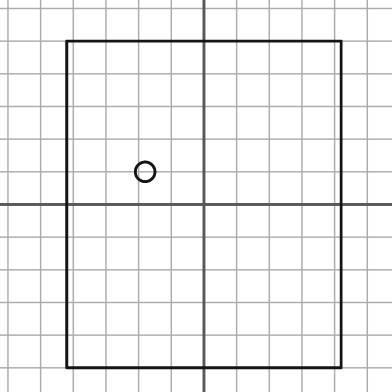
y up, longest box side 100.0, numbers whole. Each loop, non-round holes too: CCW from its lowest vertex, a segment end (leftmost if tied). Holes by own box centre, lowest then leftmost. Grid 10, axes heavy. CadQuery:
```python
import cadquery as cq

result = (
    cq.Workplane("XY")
    .moveTo(-42.0, -50.0)
    .lineTo(42.0, -50.0)
    .lineTo(42.0, 50.0)
    .lineTo(-42.0, 50.0)
    .close()
    .moveTo(-18.0, 10.0)
    .circle(3.0)
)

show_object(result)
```